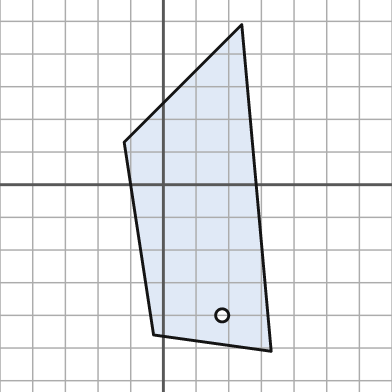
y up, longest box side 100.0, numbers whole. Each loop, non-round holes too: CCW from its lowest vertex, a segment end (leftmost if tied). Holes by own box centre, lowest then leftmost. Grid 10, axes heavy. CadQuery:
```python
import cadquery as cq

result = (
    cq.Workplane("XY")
    .moveTo(33.0, -51.0)
    .lineTo(24.0, 49.0)
    .lineTo(-12.0, 13.0)
    .lineTo(-3.0, -46.0)
    .close()
    .moveTo(18.0, -40.0)
    .circle(2.0)
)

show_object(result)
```